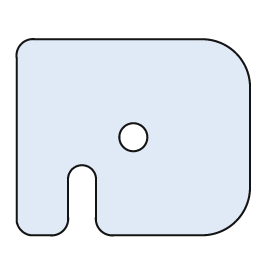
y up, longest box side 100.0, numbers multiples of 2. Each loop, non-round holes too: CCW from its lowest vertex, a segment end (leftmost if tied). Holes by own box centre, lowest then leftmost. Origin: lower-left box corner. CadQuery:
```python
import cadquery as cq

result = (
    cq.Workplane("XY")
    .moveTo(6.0, 0.0)
    .lineTo(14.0, 0.0)
    .threePointArc((20.0, 2.0), (22.0, 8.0))
    .lineTo(22.0, 24.0)
    .threePointArc((28.0, 30.0), (34.0, 24.0))
    .lineTo(34.0, 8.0)
    .threePointArc((36.0, 2.0), (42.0, 0.0))
    .lineTo(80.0, 0.0)
    .threePointArc((94.0, 6.0), (100.0, 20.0))
    .lineTo(100.0, 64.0)
    .threePointArc((94.0, 78.0), (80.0, 84.0))
    .lineTo(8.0, 84.0)
    .threePointArc((2.0, 82.0), (0.0, 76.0))
    .lineTo(0.0, 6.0)
    .threePointArc((2.0, 2.0), (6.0, 0.0))
    .close()
    .moveTo(50.0, 42.0)
    .circle(6.0)
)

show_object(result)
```